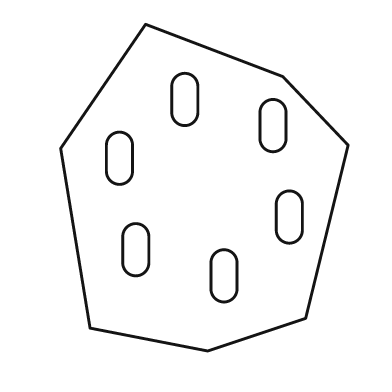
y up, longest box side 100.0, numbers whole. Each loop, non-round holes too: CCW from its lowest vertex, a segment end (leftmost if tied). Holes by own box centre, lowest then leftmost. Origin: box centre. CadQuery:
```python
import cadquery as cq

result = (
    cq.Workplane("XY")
    .moveTo(1.0, -50.0)
    .lineTo(31.0, -40.0)
    .lineTo(44.0, 13.0)
    .lineTo(24.0, 34.0)
    .lineTo(-18.0, 50.0)
    .lineTo(-44.0, 12.0)
    .lineTo(-35.0, -43.0)
    .close()
    .moveTo(2.0, -31.0)
    .threePointArc((6.0, -35.0), (10.0, -31.0))
    .lineTo(10.0, -23.0)
    .threePointArc((6.0, -19.0), (2.0, -23.0))
    .close()
    .moveTo(-25.0, -23.0)
    .threePointArc((-21.0, -27.0), (-17.0, -23.0))
    .lineTo(-17.0, -15.0)
    .threePointArc((-21.0, -11.0), (-25.0, -15.0))
    .close()
    .moveTo(22.0, -13.0)
    .threePointArc((26.0, -17.0), (30.0, -13.0))
    .lineTo(30.0, -5.0)
    .threePointArc((26.0, -1.0), (22.0, -5.0))
    .close()
    .moveTo(-30.0, 5.0)
    .threePointArc((-26.0, 1.0), (-22.0, 5.0))
    .lineTo(-22.0, 13.0)
    .threePointArc((-26.0, 17.0), (-30.0, 13.0))
    .close()
    .moveTo(17.0, 15.0)
    .threePointArc((21.0, 11.0), (25.0, 15.0))
    .lineTo(25.0, 23.0)
    .threePointArc((21.0, 27.0), (17.0, 23.0))
    .close()
    .moveTo(-10.0, 23.0)
    .threePointArc((-6.0, 19.0), (-2.0, 23.0))
    .lineTo(-2.0, 31.0)
    .threePointArc((-6.0, 35.0), (-10.0, 31.0))
    .close()
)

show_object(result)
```